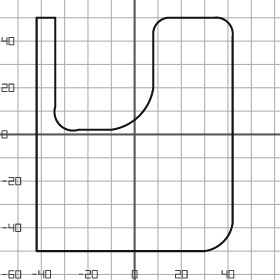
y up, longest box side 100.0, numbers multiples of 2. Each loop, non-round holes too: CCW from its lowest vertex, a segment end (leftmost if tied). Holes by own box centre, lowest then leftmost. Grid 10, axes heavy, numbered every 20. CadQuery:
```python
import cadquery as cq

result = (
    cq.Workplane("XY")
    .moveTo(-42.0, -50.0)
    .lineTo(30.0, -50.0)
    .threePointArc((38.0, -46.0), (42.0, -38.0))
    .lineTo(42.0, 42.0)
    .threePointArc((40.0, 48.0), (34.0, 50.0))
    .lineTo(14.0, 50.0)
    .threePointArc((10.0, 48.0), (8.0, 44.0))
    .lineTo(8.0, 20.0)
    .threePointArc((2.0, 8.0), (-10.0, 2.0))
    .lineTo(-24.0, 2.0)
    .threePointArc((-32.0, 4.0), (-34.0, 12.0))
    .lineTo(-34.0, 50.0)
    .lineTo(-42.0, 50.0)
    .close()
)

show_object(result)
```